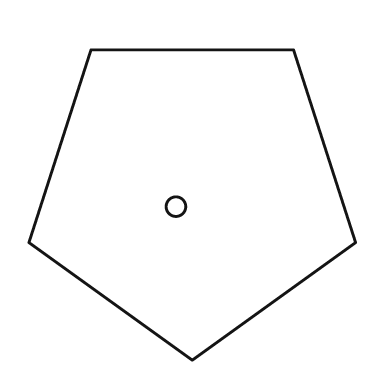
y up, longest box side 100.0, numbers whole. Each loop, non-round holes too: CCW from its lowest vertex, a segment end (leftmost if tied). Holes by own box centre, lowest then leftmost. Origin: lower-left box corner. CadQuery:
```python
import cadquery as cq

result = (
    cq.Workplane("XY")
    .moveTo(50.0, 0.0)
    .lineTo(100.0, 36.0)
    .lineTo(81.0, 95.0)
    .lineTo(19.0, 95.0)
    .lineTo(0.0, 36.0)
    .close()
    .moveTo(45.0, 47.0)
    .circle(3.0)
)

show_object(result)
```